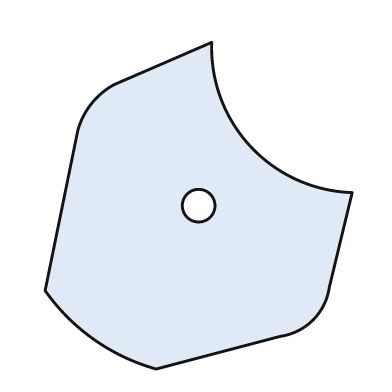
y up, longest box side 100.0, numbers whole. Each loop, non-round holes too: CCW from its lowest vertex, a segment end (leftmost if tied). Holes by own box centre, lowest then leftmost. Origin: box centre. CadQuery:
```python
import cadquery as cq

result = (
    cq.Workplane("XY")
    .moveTo(-13.0, -50.0)
    .lineTo(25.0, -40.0)
    .threePointArc((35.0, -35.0), (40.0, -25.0))
    .lineTo(47.0, 4.0)
    .threePointArc((16.0, 18.0), (4.0, 50.0))
    .lineTo(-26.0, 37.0)
    .threePointArc((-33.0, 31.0), (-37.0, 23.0))
    .lineTo(-47.0, -26.0)
    .threePointArc((-32.0, -41.0), (-13.0, -50.0))
    .close()
    .moveTo(0.0, 0.0)
    .circle(5.0)
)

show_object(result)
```